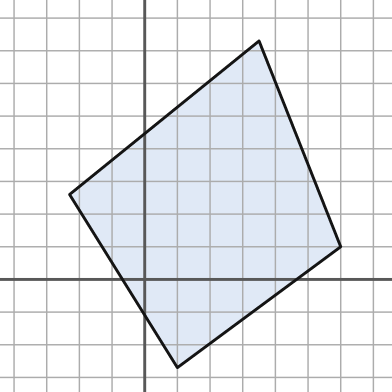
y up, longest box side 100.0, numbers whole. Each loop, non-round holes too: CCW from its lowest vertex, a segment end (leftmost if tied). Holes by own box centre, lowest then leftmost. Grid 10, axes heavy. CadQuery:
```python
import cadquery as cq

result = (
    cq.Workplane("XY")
    .moveTo(10.0, -27.0)
    .lineTo(60.0, 10.0)
    .lineTo(35.0, 73.0)
    .lineTo(-23.0, 26.0)
    .close()
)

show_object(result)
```